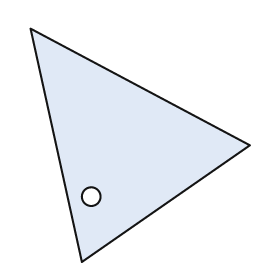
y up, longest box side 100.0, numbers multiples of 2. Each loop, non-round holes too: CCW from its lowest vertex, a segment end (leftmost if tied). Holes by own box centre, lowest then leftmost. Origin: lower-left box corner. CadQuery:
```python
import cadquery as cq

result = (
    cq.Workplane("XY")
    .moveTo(22.0, 0.0)
    .lineTo(94.0, 50.0)
    .lineTo(0.0, 100.0)
    .close()
    .moveTo(26.0, 28.0)
    .circle(4.0)
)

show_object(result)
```